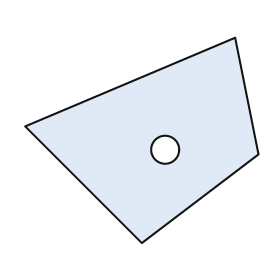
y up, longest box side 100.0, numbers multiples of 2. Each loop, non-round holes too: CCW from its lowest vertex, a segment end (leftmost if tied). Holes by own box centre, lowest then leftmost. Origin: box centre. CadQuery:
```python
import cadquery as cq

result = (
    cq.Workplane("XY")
    .moveTo(0.0, -44.0)
    .lineTo(50.0, -6.0)
    .lineTo(40.0, 44.0)
    .lineTo(-50.0, 6.0)
    .close()
    .moveTo(10.0, -4.0)
    .circle(6.0)
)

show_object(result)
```